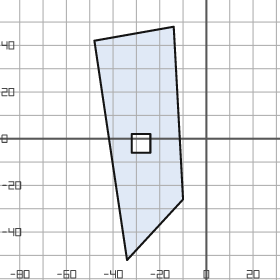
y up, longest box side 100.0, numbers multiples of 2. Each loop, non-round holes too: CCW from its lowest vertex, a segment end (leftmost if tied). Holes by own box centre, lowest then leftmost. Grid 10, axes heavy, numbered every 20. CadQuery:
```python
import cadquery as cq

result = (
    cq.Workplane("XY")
    .moveTo(-34.0, -52.0)
    .lineTo(-10.0, -26.0)
    .lineTo(-14.0, 48.0)
    .lineTo(-48.0, 42.0)
    .close()
    .moveTo(-32.0, -6.0)
    .lineTo(-24.0, -6.0)
    .lineTo(-24.0, 2.0)
    .lineTo(-32.0, 2.0)
    .close()
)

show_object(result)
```